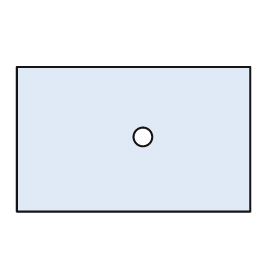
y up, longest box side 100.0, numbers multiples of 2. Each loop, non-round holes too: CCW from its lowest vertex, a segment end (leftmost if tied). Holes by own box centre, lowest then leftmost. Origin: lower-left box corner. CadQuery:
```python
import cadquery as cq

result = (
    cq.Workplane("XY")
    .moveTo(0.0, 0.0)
    .lineTo(100.0, 0.0)
    .lineTo(100.0, 62.0)
    .lineTo(0.0, 62.0)
    .close()
    .moveTo(54.0, 32.0)
    .circle(4.0)
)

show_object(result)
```